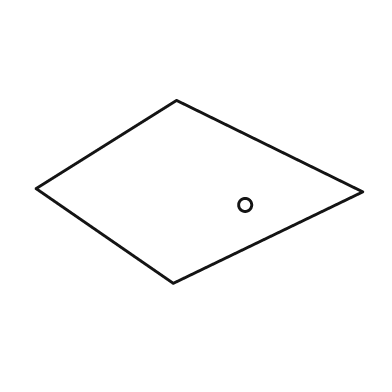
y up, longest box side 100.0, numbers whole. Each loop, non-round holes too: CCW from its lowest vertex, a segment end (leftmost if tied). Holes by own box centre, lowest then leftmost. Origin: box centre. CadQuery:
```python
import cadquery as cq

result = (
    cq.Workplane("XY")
    .moveTo(-8.0, -28.0)
    .lineTo(50.0, 0.0)
    .lineTo(-7.0, 28.0)
    .lineTo(-50.0, 1.0)
    .close()
    .moveTo(14.0, -4.0)
    .circle(2.0)
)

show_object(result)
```